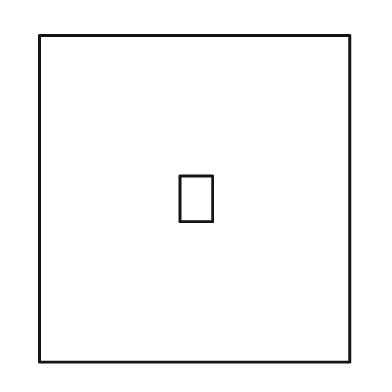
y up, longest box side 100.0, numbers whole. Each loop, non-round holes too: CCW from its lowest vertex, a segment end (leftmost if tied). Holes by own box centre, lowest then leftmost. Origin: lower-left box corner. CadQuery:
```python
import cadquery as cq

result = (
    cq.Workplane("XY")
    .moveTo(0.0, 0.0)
    .lineTo(95.0, 0.0)
    .lineTo(95.0, 100.0)
    .lineTo(0.0, 100.0)
    .close()
    .moveTo(43.0, 43.0)
    .lineTo(53.0, 43.0)
    .lineTo(53.0, 57.0)
    .lineTo(43.0, 57.0)
    .close()
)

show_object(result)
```